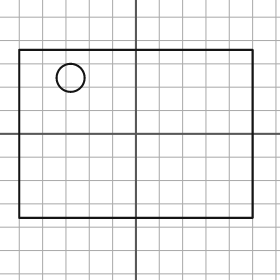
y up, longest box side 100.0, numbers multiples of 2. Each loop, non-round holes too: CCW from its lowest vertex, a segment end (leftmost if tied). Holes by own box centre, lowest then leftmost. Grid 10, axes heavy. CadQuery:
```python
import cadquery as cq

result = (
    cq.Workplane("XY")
    .moveTo(-50.0, -36.0)
    .lineTo(50.0, -36.0)
    .lineTo(50.0, 36.0)
    .lineTo(-50.0, 36.0)
    .close()
    .moveTo(-28.0, 24.0)
    .circle(6.0)
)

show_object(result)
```